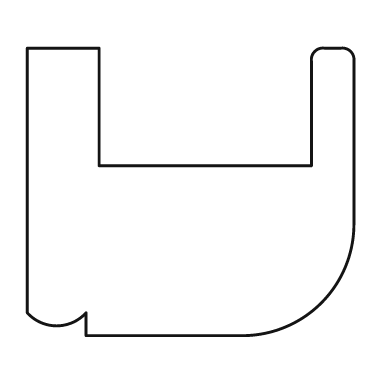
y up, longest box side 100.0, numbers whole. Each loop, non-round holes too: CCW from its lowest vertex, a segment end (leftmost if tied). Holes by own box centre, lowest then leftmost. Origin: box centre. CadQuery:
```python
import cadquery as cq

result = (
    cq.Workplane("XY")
    .moveTo(-32.0, -44.0)
    .lineTo(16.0, -44.0)
    .threePointArc((40.0, -34.0), (50.0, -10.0))
    .lineTo(50.0, 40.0)
    .threePointArc((49.0, 43.0), (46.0, 44.0))
    .lineTo(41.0, 44.0)
    .threePointArc((38.0, 43.0), (37.0, 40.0))
    .lineTo(37.0, 8.0)
    .lineTo(-28.0, 8.0)
    .lineTo(-28.0, 44.0)
    .lineTo(-50.0, 44.0)
    .lineTo(-50.0, -37.0)
    .threePointArc((-41.0, -41.0), (-32.0, -37.0))
    .close()
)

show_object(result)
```